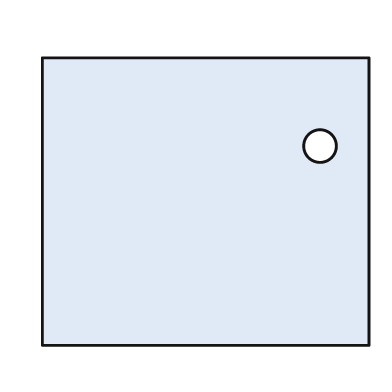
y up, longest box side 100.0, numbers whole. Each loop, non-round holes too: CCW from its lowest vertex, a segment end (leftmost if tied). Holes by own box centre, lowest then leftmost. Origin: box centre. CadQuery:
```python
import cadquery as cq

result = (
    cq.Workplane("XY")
    .moveTo(-50.0, -44.0)
    .lineTo(50.0, -44.0)
    .lineTo(50.0, 44.0)
    .lineTo(-50.0, 44.0)
    .close()
    .moveTo(35.0, 17.0)
    .circle(5.0)
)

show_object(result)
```